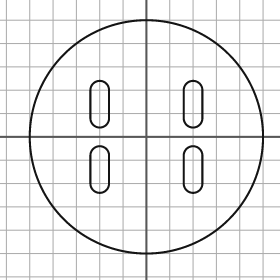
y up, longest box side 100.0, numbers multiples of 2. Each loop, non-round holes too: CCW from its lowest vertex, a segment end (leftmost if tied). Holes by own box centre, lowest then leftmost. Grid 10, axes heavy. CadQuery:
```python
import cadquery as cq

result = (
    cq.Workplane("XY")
    .moveTo(0.0, 0.0)
    .circle(50.0)
    .moveTo(-24.0, -20.0)
    .threePointArc((-20.0, -24.0), (-16.0, -20.0))
    .lineTo(-16.0, -8.0)
    .threePointArc((-20.0, -4.0), (-24.0, -8.0))
    .close()
    .moveTo(16.0, -20.0)
    .threePointArc((20.0, -24.0), (24.0, -20.0))
    .lineTo(24.0, -8.0)
    .threePointArc((20.0, -4.0), (16.0, -8.0))
    .close()
    .moveTo(-24.0, 8.0)
    .threePointArc((-20.0, 4.0), (-16.0, 8.0))
    .lineTo(-16.0, 20.0)
    .threePointArc((-20.0, 24.0), (-24.0, 20.0))
    .close()
    .moveTo(16.0, 8.0)
    .threePointArc((20.0, 4.0), (24.0, 8.0))
    .lineTo(24.0, 20.0)
    .threePointArc((20.0, 24.0), (16.0, 20.0))
    .close()
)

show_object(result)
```